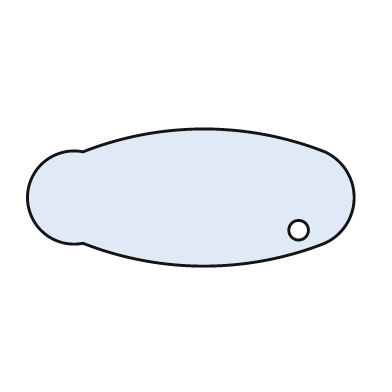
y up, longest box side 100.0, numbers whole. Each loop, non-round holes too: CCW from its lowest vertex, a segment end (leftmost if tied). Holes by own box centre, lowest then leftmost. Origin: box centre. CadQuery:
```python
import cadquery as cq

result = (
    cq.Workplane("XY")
    .moveTo(-33.0, -14.0)
    .threePointArc((4.0, -21.0), (41.0, -14.0))
    .threePointArc((50.0, 0.0), (41.0, 14.0))
    .threePointArc((4.0, 21.0), (-33.0, 14.0))
    .threePointArc((-50.0, 0.0), (-33.0, -14.0))
    .close()
    .moveTo(33.0, -10.0)
    .circle(3.0)
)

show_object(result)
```